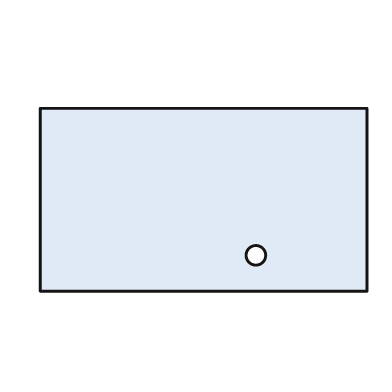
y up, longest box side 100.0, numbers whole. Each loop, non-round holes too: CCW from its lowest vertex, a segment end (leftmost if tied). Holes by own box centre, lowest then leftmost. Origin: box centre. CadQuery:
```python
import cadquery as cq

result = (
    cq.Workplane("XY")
    .moveTo(-50.0, -28.0)
    .lineTo(50.0, -28.0)
    .lineTo(50.0, 28.0)
    .lineTo(-50.0, 28.0)
    .close()
    .moveTo(16.0, -17.0)
    .circle(3.0)
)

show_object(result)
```